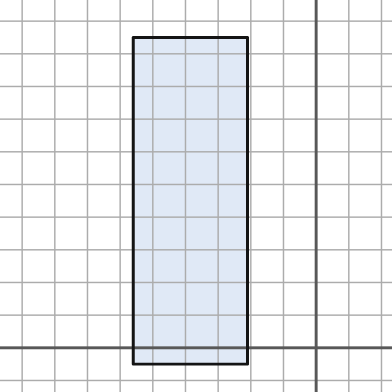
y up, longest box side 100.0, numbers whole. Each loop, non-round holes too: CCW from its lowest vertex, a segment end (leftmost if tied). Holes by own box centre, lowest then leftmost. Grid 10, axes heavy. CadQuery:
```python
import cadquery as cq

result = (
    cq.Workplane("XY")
    .moveTo(-56.0, -5.0)
    .lineTo(-21.0, -5.0)
    .lineTo(-21.0, 95.0)
    .lineTo(-56.0, 95.0)
    .close()
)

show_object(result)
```